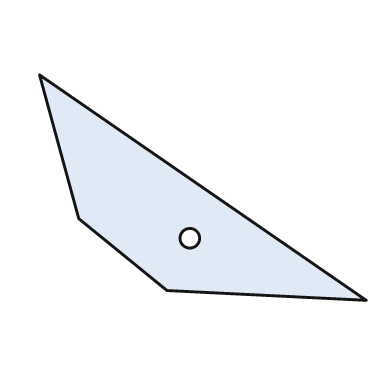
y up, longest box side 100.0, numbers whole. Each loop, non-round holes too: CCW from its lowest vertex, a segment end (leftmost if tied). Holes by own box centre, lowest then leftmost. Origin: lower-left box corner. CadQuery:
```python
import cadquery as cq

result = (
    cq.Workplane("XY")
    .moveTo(100.0, 0.0)
    .lineTo(0.0, 69.0)
    .lineTo(12.0, 25.0)
    .lineTo(39.0, 3.0)
    .close()
    .moveTo(46.0, 19.0)
    .circle(3.0)
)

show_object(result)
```